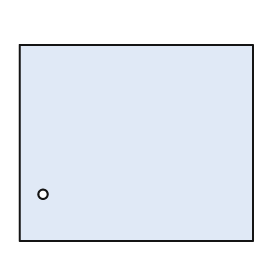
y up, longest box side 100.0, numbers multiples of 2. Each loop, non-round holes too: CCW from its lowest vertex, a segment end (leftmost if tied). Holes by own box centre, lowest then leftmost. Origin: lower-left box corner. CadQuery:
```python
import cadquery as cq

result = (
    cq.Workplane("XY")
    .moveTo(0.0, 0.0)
    .lineTo(100.0, 0.0)
    .lineTo(100.0, 84.0)
    .lineTo(0.0, 84.0)
    .close()
    .moveTo(10.0, 20.0)
    .circle(2.0)
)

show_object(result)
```